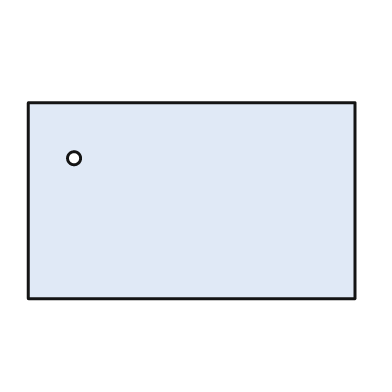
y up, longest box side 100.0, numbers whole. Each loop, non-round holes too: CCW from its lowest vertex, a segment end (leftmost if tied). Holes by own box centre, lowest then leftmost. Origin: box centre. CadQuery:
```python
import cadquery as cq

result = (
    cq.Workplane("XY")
    .moveTo(-50.0, -30.0)
    .lineTo(50.0, -30.0)
    .lineTo(50.0, 30.0)
    .lineTo(-50.0, 30.0)
    .close()
    .moveTo(-36.0, 13.0)
    .circle(2.0)
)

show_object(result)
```